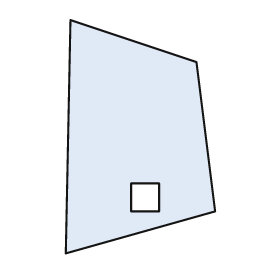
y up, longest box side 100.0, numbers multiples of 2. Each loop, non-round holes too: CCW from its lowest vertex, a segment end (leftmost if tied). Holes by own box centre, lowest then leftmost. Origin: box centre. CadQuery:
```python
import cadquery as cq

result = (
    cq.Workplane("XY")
    .moveTo(-32.0, -50.0)
    .lineTo(32.0, -32.0)
    .lineTo(24.0, 32.0)
    .lineTo(-30.0, 50.0)
    .close()
    .moveTo(-4.0, -32.0)
    .lineTo(8.0, -32.0)
    .lineTo(8.0, -20.0)
    .lineTo(-4.0, -20.0)
    .close()
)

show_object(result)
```